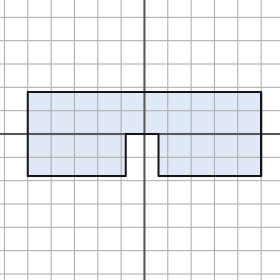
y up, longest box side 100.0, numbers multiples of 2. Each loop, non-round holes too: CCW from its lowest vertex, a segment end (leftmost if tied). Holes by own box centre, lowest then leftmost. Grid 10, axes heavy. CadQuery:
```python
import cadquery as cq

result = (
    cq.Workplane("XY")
    .moveTo(-50.0, -18.0)
    .lineTo(-8.0, -18.0)
    .lineTo(-8.0, 0.0)
    .lineTo(6.0, 0.0)
    .lineTo(6.0, -18.0)
    .lineTo(50.0, -18.0)
    .lineTo(50.0, 18.0)
    .lineTo(-50.0, 18.0)
    .close()
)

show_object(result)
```